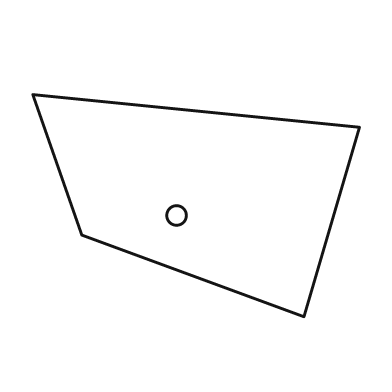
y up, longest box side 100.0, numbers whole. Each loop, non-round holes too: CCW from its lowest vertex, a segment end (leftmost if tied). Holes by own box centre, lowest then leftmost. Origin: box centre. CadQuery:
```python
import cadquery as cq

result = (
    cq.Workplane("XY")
    .moveTo(33.0, -34.0)
    .lineTo(50.0, 24.0)
    .lineTo(-50.0, 34.0)
    .lineTo(-35.0, -9.0)
    .close()
    .moveTo(-6.0, -3.0)
    .circle(3.0)
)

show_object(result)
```